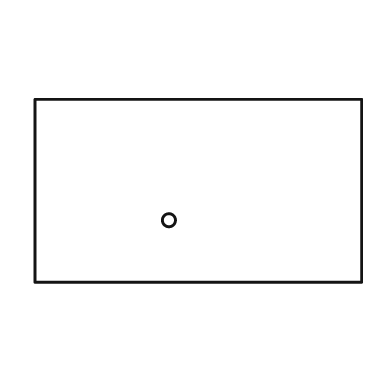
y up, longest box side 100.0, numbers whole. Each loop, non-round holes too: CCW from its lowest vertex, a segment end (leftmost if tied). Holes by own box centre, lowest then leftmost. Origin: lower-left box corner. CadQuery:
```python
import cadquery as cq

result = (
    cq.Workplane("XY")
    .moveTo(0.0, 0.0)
    .lineTo(100.0, 0.0)
    .lineTo(100.0, 56.0)
    .lineTo(0.0, 56.0)
    .close()
    .moveTo(41.0, 19.0)
    .circle(2.0)
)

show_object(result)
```